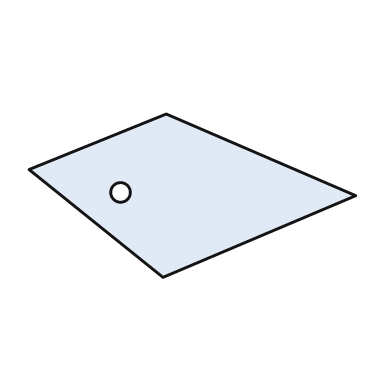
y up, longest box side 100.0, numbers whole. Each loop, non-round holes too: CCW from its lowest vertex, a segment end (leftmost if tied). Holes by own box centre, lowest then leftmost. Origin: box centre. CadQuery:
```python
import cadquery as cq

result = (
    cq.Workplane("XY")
    .moveTo(-9.0, -25.0)
    .lineTo(50.0, 0.0)
    .lineTo(-8.0, 25.0)
    .lineTo(-50.0, 8.0)
    .close()
    .moveTo(-22.0, 1.0)
    .circle(3.0)
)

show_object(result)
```